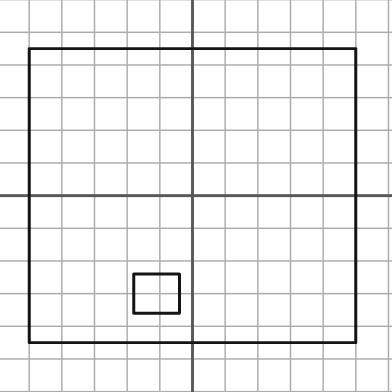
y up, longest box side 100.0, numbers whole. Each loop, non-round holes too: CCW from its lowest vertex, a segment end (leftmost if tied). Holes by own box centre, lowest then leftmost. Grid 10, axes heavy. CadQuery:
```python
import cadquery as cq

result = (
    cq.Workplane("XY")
    .moveTo(-50.0, -45.0)
    .lineTo(50.0, -45.0)
    .lineTo(50.0, 45.0)
    .lineTo(-50.0, 45.0)
    .close()
    .moveTo(-18.0, -36.0)
    .lineTo(-4.0, -36.0)
    .lineTo(-4.0, -24.0)
    .lineTo(-18.0, -24.0)
    .close()
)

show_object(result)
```